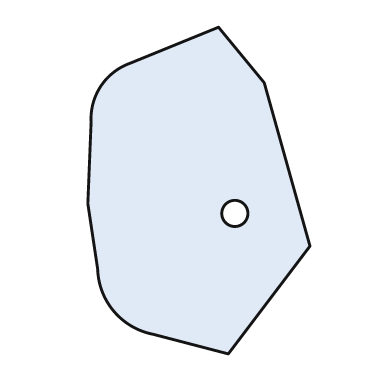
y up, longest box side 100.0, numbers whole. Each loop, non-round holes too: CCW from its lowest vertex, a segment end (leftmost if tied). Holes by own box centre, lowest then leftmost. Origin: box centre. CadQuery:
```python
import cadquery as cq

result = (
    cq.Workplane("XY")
    .moveTo(9.0, -50.0)
    .lineTo(34.0, -17.0)
    .lineTo(20.0, 33.0)
    .lineTo(6.0, 50.0)
    .lineTo(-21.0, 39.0)
    .threePointArc((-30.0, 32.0), (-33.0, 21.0))
    .lineTo(-34.0, -4.0)
    .lineTo(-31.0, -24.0)
    .threePointArc((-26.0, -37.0), (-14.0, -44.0))
    .close()
    .moveTo(11.0, -7.0)
    .circle(4.0)
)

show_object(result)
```